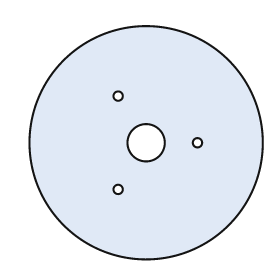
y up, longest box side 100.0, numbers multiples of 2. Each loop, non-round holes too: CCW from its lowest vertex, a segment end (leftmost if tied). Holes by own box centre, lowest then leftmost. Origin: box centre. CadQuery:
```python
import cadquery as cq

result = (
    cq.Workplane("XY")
    .moveTo(0.0, 0.0)
    .circle(50.0)
    .moveTo(-12.0, -20.0)
    .circle(2.0)
    .moveTo(0.0, 0.0)
    .circle(8.0)
    .moveTo(22.0, 0.0)
    .circle(2.0)
    .moveTo(-12.0, 20.0)
    .circle(2.0)
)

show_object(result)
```